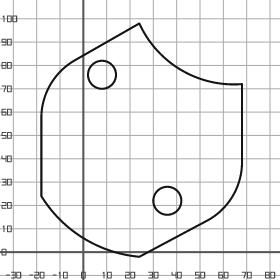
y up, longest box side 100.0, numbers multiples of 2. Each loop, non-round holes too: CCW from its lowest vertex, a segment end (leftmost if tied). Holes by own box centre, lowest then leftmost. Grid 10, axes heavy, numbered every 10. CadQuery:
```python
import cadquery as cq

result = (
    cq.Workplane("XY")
    .moveTo(24.0, -2.0)
    .lineTo(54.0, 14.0)
    .threePointArc((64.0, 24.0), (68.0, 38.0))
    .lineTo(68.0, 72.0)
    .threePointArc((42.0, 78.0), (24.0, 98.0))
    .lineTo(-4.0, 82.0)
    .threePointArc((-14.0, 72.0), (-18.0, 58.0))
    .lineTo(-18.0, 24.0)
    .threePointArc((0.0, 6.0), (24.0, -2.0))
    .close()
    .moveTo(36.0, 22.0)
    .circle(6.0)
    .moveTo(8.0, 76.0)
    .circle(6.0)
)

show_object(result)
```